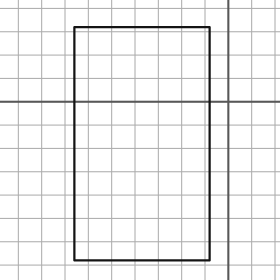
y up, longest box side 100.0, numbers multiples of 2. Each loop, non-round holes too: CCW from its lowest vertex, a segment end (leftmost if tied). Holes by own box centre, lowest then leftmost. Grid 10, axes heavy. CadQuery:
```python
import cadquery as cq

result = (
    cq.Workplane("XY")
    .moveTo(-66.0, -68.0)
    .lineTo(-8.0, -68.0)
    .lineTo(-8.0, 32.0)
    .lineTo(-66.0, 32.0)
    .close()
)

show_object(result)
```